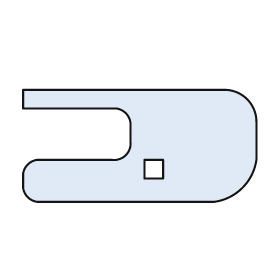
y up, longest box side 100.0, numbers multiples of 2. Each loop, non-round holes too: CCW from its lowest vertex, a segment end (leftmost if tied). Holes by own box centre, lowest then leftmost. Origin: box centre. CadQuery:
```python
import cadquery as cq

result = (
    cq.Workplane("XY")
    .moveTo(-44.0, -24.0)
    .lineTo(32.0, -24.0)
    .threePointArc((44.0, -18.0), (50.0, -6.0))
    .lineTo(50.0, 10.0)
    .threePointArc((46.0, 20.0), (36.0, 24.0))
    .lineTo(-50.0, 24.0)
    .lineTo(-50.0, 16.0)
    .lineTo(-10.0, 16.0)
    .threePointArc((-6.0, 14.0), (-4.0, 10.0))
    .lineTo(-4.0, 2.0)
    .threePointArc((-6.0, -4.0), (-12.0, -6.0))
    .lineTo(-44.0, -6.0)
    .threePointArc((-48.0, -8.0), (-50.0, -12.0))
    .lineTo(-50.0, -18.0)
    .threePointArc((-48.0, -22.0), (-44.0, -24.0))
    .close()
    .moveTo(2.0, -14.0)
    .lineTo(10.0, -14.0)
    .lineTo(10.0, -6.0)
    .lineTo(2.0, -6.0)
    .close()
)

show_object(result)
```